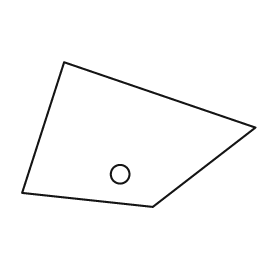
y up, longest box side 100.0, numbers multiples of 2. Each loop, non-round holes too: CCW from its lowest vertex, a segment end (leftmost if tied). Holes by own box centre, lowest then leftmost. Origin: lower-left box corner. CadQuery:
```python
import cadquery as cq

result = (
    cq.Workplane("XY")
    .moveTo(56.0, 0.0)
    .lineTo(100.0, 34.0)
    .lineTo(18.0, 62.0)
    .lineTo(0.0, 6.0)
    .close()
    .moveTo(42.0, 14.0)
    .circle(4.0)
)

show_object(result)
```